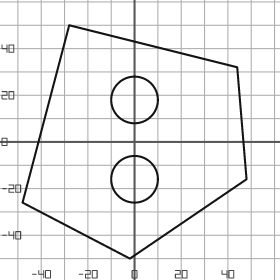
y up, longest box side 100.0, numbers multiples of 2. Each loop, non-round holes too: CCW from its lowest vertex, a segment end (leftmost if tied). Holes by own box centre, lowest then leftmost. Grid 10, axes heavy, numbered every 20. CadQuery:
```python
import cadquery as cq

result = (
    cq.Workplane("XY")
    .moveTo(-2.0, -50.0)
    .lineTo(48.0, -16.0)
    .lineTo(44.0, 32.0)
    .lineTo(-28.0, 50.0)
    .lineTo(-48.0, -26.0)
    .close()
    .moveTo(0.0, -16.0)
    .circle(10.0)
    .moveTo(0.0, 18.0)
    .circle(10.0)
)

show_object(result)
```